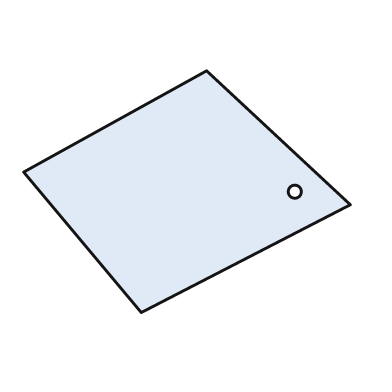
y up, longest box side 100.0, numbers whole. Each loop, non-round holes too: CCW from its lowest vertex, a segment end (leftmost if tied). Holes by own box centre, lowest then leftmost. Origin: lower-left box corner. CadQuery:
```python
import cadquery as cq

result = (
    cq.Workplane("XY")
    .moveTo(36.0, 0.0)
    .lineTo(100.0, 33.0)
    .lineTo(56.0, 74.0)
    .lineTo(0.0, 43.0)
    .close()
    .moveTo(83.0, 37.0)
    .circle(2.0)
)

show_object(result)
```